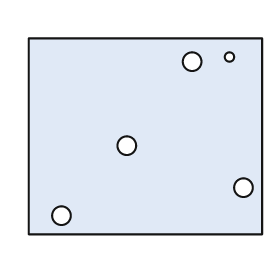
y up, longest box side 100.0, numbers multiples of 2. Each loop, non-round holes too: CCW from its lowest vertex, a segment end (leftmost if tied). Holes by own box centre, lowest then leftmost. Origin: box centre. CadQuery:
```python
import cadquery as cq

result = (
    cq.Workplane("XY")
    .moveTo(-50.0, -42.0)
    .lineTo(50.0, -42.0)
    .lineTo(50.0, 42.0)
    .lineTo(-50.0, 42.0)
    .close()
    .moveTo(-36.0, -34.0)
    .circle(4.0)
    .moveTo(42.0, -22.0)
    .circle(4.0)
    .moveTo(-8.0, -4.0)
    .circle(4.0)
    .moveTo(20.0, 32.0)
    .circle(4.0)
    .moveTo(36.0, 34.0)
    .circle(2.0)
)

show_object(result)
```